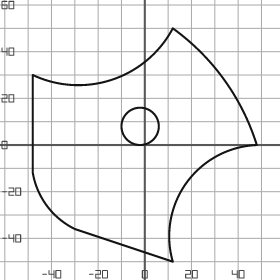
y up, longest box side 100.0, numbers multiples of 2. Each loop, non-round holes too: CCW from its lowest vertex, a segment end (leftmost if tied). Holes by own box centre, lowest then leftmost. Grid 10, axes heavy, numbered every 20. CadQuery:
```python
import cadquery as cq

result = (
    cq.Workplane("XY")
    .moveTo(12.0, -50.0)
    .threePointArc((18.0, -16.0), (48.0, 0.0))
    .threePointArc((34.0, 28.0), (12.0, 50.0))
    .threePointArc((-14.0, 28.0), (-48.0, 30.0))
    .lineTo(-48.0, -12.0)
    .threePointArc((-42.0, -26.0), (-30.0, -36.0))
    .close()
    .moveTo(-2.0, 8.0)
    .circle(8.0)
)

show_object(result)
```